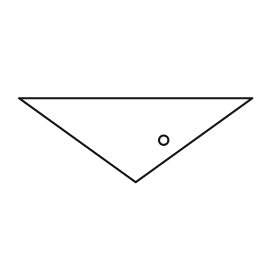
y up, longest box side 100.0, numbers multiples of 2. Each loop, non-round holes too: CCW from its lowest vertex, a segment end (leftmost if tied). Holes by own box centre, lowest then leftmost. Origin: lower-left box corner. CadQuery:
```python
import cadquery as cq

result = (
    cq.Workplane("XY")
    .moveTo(50.0, 0.0)
    .lineTo(100.0, 36.0)
    .lineTo(0.0, 36.0)
    .close()
    .moveTo(62.0, 18.0)
    .circle(2.0)
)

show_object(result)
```